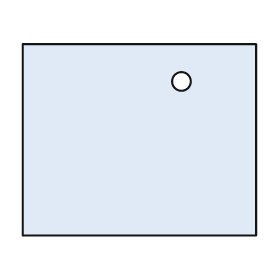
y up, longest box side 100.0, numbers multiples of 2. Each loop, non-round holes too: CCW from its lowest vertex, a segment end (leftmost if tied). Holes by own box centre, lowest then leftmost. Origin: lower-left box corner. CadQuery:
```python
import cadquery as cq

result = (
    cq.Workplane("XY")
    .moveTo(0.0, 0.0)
    .lineTo(100.0, 0.0)
    .lineTo(100.0, 82.0)
    .lineTo(0.0, 82.0)
    .close()
    .moveTo(68.0, 66.0)
    .circle(4.0)
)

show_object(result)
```